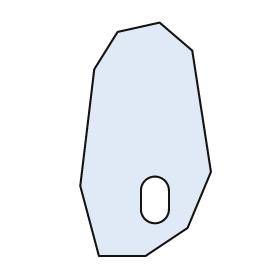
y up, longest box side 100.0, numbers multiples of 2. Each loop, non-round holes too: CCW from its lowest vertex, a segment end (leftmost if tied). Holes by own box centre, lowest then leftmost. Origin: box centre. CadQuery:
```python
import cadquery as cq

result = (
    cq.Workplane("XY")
    .moveTo(-20.0, -50.0)
    .lineTo(0.0, -50.0)
    .lineTo(18.0, -38.0)
    .lineTo(28.0, -14.0)
    .lineTo(20.0, 38.0)
    .lineTo(6.0, 50.0)
    .lineTo(-12.0, 46.0)
    .lineTo(-22.0, 30.0)
    .lineTo(-28.0, -20.0)
    .close()
    .moveTo(-2.0, -30.0)
    .threePointArc((4.0, -36.0), (10.0, -30.0))
    .lineTo(10.0, -22.0)
    .threePointArc((4.0, -16.0), (-2.0, -22.0))
    .close()
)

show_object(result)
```